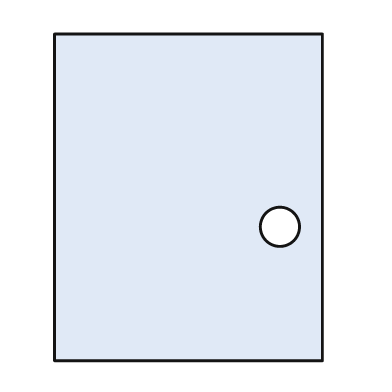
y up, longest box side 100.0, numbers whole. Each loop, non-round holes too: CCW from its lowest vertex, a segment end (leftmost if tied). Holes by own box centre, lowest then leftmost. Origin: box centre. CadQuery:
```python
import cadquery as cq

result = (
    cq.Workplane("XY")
    .moveTo(-41.0, -50.0)
    .lineTo(41.0, -50.0)
    .lineTo(41.0, 50.0)
    .lineTo(-41.0, 50.0)
    .close()
    .moveTo(28.0, -9.0)
    .circle(6.0)
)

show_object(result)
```